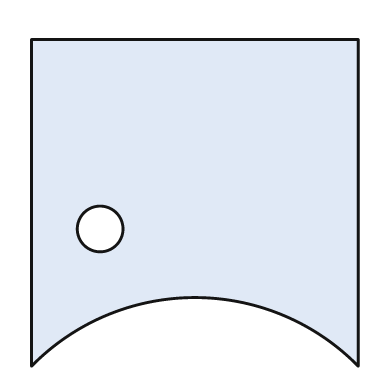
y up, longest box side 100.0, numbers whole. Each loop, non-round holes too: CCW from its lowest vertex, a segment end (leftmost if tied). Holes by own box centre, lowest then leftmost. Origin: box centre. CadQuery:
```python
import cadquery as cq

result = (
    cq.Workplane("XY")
    .moveTo(-50.0, -50.0)
    .threePointArc((0.0, -29.0), (50.0, -50.0))
    .lineTo(50.0, 50.0)
    .lineTo(-50.0, 50.0)
    .close()
    .moveTo(-29.0, -8.0)
    .circle(7.0)
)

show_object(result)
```